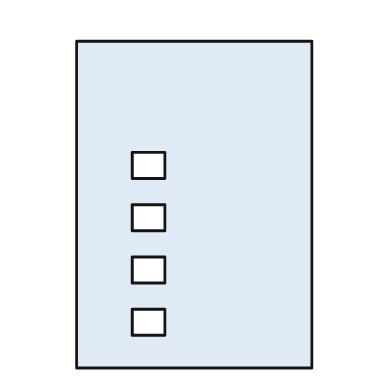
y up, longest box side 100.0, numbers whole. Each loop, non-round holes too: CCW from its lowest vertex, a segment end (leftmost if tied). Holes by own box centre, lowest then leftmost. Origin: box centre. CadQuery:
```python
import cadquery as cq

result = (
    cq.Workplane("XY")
    .moveTo(-36.0, -50.0)
    .lineTo(36.0, -50.0)
    .lineTo(36.0, 50.0)
    .lineTo(-36.0, 50.0)
    .close()
    .moveTo(-19.0, -40.0)
    .lineTo(-9.0, -40.0)
    .lineTo(-9.0, -32.0)
    .lineTo(-19.0, -32.0)
    .close()
    .moveTo(-19.0, -24.0)
    .lineTo(-9.0, -24.0)
    .lineTo(-9.0, -16.0)
    .lineTo(-19.0, -16.0)
    .close()
    .moveTo(-19.0, -8.0)
    .lineTo(-9.0, -8.0)
    .lineTo(-9.0, 0.0)
    .lineTo(-19.0, 0.0)
    .close()
    .moveTo(-19.0, 8.0)
    .lineTo(-9.0, 8.0)
    .lineTo(-9.0, 16.0)
    .lineTo(-19.0, 16.0)
    .close()
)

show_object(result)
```